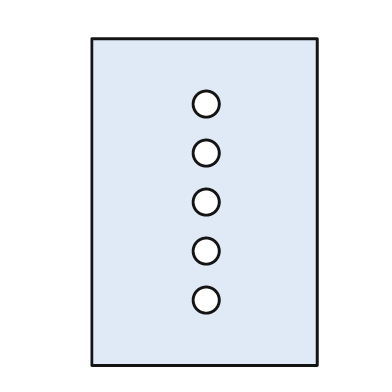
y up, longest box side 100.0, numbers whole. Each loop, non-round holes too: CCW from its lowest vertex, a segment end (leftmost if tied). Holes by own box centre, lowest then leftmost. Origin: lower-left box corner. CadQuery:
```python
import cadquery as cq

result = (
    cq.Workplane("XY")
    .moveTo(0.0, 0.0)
    .lineTo(69.0, 0.0)
    .lineTo(69.0, 100.0)
    .lineTo(0.0, 100.0)
    .close()
    .moveTo(35.0, 20.0)
    .circle(4.0)
    .moveTo(35.0, 35.0)
    .circle(4.0)
    .moveTo(35.0, 50.0)
    .circle(4.0)
    .moveTo(35.0, 65.0)
    .circle(4.0)
    .moveTo(35.0, 80.0)
    .circle(4.0)
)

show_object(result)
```